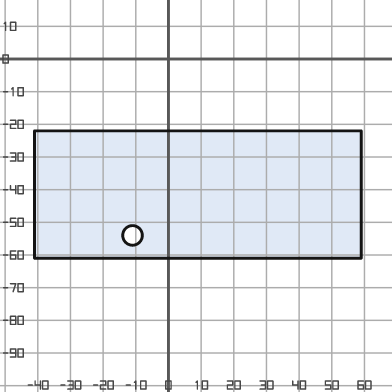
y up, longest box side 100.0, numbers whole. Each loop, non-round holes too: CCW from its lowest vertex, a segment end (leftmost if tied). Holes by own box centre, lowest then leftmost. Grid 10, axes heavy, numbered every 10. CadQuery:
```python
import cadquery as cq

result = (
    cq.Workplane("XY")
    .moveTo(-41.0, -61.0)
    .lineTo(59.0, -61.0)
    .lineTo(59.0, -22.0)
    .lineTo(-41.0, -22.0)
    .close()
    .moveTo(-11.0, -54.0)
    .circle(3.0)
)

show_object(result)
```